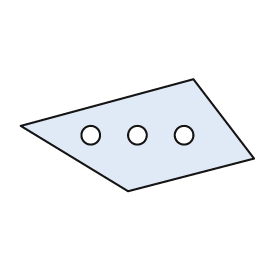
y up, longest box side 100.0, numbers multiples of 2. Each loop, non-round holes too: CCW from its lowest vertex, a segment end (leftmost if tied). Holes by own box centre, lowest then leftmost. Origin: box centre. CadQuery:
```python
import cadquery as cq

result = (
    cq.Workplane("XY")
    .moveTo(-4.0, -24.0)
    .lineTo(50.0, -10.0)
    .lineTo(24.0, 24.0)
    .lineTo(-50.0, 4.0)
    .close()
    .moveTo(-20.0, 0.0)
    .circle(4.0)
    .moveTo(0.0, 0.0)
    .circle(4.0)
    .moveTo(20.0, 0.0)
    .circle(4.0)
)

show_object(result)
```